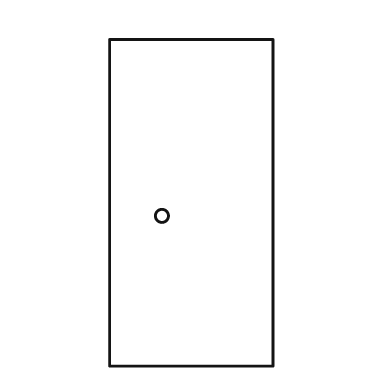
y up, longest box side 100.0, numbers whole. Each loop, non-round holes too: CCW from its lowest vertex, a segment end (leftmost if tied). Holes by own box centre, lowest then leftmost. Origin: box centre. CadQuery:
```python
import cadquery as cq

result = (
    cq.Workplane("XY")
    .moveTo(-25.0, -50.0)
    .lineTo(25.0, -50.0)
    .lineTo(25.0, 50.0)
    .lineTo(-25.0, 50.0)
    .close()
    .moveTo(-9.0, -4.0)
    .circle(2.0)
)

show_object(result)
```